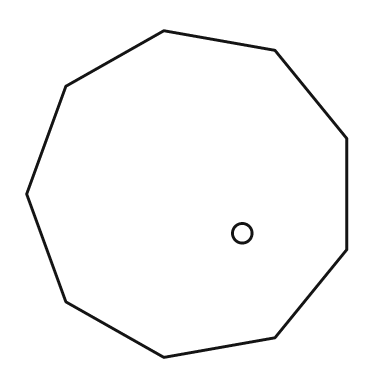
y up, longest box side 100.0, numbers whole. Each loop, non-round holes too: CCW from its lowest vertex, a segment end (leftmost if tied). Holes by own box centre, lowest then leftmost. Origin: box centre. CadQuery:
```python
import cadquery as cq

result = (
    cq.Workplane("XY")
    .moveTo(-7.0, -50.0)
    .lineTo(27.0, -44.0)
    .lineTo(49.0, -17.0)
    .lineTo(49.0, 17.0)
    .lineTo(27.0, 44.0)
    .lineTo(-7.0, 50.0)
    .lineTo(-37.0, 33.0)
    .lineTo(-49.0, 0.0)
    .lineTo(-37.0, -33.0)
    .close()
    .moveTo(17.0, -12.0)
    .circle(3.0)
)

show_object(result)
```